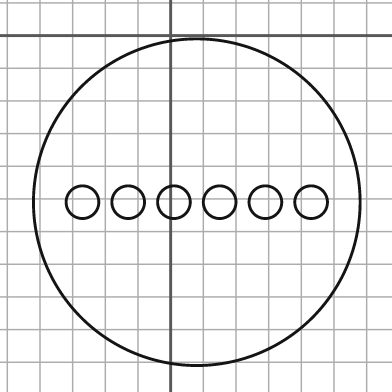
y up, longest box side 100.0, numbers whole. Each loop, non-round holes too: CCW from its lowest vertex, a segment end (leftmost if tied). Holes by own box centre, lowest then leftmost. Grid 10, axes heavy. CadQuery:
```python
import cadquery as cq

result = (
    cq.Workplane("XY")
    .moveTo(8.0, -51.0)
    .circle(50.0)
    .moveTo(-27.0, -51.0)
    .circle(5.0)
    .moveTo(-13.0, -51.0)
    .circle(5.0)
    .moveTo(1.0, -51.0)
    .circle(5.0)
    .moveTo(15.0, -51.0)
    .circle(5.0)
    .moveTo(29.0, -51.0)
    .circle(5.0)
    .moveTo(43.0, -51.0)
    .circle(5.0)
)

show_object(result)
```